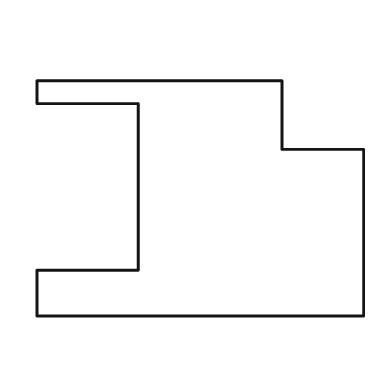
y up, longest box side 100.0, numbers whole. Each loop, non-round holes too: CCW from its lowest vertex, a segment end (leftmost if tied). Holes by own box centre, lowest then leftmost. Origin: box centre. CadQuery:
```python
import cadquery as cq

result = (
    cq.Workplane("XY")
    .moveTo(-50.0, -36.0)
    .lineTo(50.0, -36.0)
    .lineTo(50.0, 15.0)
    .lineTo(25.0, 15.0)
    .lineTo(25.0, 36.0)
    .lineTo(-50.0, 36.0)
    .lineTo(-50.0, 29.0)
    .lineTo(-19.0, 29.0)
    .lineTo(-19.0, -22.0)
    .lineTo(-50.0, -22.0)
    .close()
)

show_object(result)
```